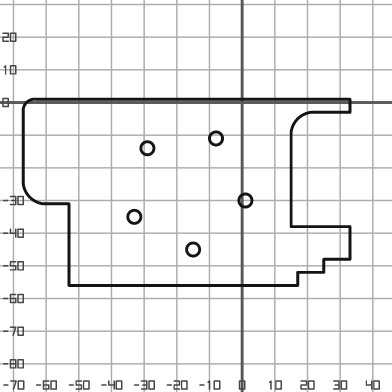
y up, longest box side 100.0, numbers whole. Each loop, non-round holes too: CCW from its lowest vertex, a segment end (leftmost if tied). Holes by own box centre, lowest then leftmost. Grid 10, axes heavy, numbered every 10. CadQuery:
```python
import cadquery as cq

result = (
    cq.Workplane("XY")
    .moveTo(-53.0, -56.0)
    .lineTo(17.0, -56.0)
    .lineTo(17.0, -52.0)
    .lineTo(25.0, -52.0)
    .lineTo(25.0, -48.0)
    .lineTo(33.0, -48.0)
    .lineTo(33.0, -38.0)
    .lineTo(15.0, -38.0)
    .lineTo(15.0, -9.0)
    .threePointArc((17.0, -5.0), (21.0, -3.0))
    .lineTo(33.0, -3.0)
    .lineTo(33.0, 1.0)
    .lineTo(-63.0, 1.0)
    .threePointArc((-66.0, 0.0), (-67.0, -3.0))
    .lineTo(-67.0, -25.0)
    .threePointArc((-65.0, -29.0), (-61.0, -31.0))
    .lineTo(-53.0, -31.0)
    .close()
    .moveTo(-15.0, -45.0)
    .circle(2.0)
    .moveTo(-33.0, -35.0)
    .circle(2.0)
    .moveTo(1.0, -30.0)
    .circle(2.0)
    .moveTo(-29.0, -14.0)
    .circle(2.0)
    .moveTo(-8.0, -11.0)
    .circle(2.0)
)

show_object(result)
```